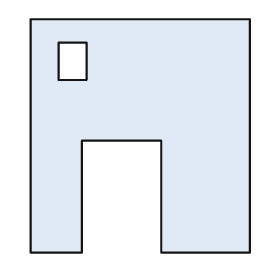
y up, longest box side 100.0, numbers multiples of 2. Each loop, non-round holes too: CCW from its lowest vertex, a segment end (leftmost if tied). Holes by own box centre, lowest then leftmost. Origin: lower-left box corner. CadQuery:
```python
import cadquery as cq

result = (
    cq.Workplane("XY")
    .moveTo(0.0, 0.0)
    .lineTo(22.0, 0.0)
    .lineTo(22.0, 48.0)
    .lineTo(56.0, 48.0)
    .lineTo(56.0, 0.0)
    .lineTo(94.0, 0.0)
    .lineTo(94.0, 100.0)
    .lineTo(0.0, 100.0)
    .close()
    .moveTo(12.0, 74.0)
    .lineTo(24.0, 74.0)
    .lineTo(24.0, 90.0)
    .lineTo(12.0, 90.0)
    .close()
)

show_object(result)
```